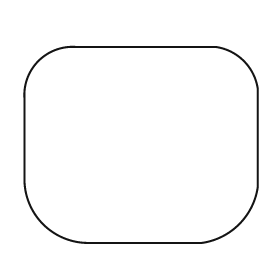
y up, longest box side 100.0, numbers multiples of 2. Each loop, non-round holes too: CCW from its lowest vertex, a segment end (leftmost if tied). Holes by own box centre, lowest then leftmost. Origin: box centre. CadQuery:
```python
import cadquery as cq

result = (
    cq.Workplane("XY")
    .moveTo(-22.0, -42.0)
    .lineTo(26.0, -42.0)
    .threePointArc((42.0, -34.0), (50.0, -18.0))
    .lineTo(50.0, 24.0)
    .threePointArc((44.0, 36.0), (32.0, 42.0))
    .lineTo(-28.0, 42.0)
    .threePointArc((-44.0, 36.0), (-50.0, 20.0))
    .lineTo(-50.0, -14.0)
    .threePointArc((-42.0, -34.0), (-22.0, -42.0))
    .close()
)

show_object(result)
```